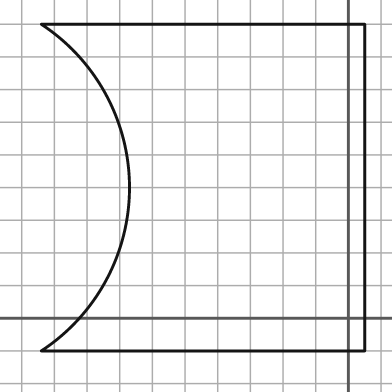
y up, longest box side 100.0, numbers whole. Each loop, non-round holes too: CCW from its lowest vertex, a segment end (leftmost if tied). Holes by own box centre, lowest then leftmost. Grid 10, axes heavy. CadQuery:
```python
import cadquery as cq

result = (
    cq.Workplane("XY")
    .moveTo(-94.0, -10.0)
    .lineTo(5.0, -10.0)
    .lineTo(5.0, 90.0)
    .lineTo(-94.0, 90.0)
    .threePointArc((-67.0, 40.0), (-94.0, -10.0))
    .close()
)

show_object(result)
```